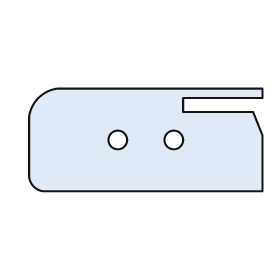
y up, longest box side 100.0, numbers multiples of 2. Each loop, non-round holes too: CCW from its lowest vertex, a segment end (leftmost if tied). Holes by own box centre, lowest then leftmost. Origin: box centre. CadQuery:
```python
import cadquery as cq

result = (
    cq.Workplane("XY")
    .moveTo(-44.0, -22.0)
    .lineTo(50.0, -22.0)
    .lineTo(50.0, 2.0)
    .lineTo(46.0, 12.0)
    .lineTo(16.0, 12.0)
    .lineTo(16.0, 18.0)
    .lineTo(50.0, 18.0)
    .lineTo(50.0, 22.0)
    .lineTo(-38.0, 22.0)
    .threePointArc((-46.0, 18.0), (-50.0, 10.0))
    .lineTo(-50.0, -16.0)
    .threePointArc((-48.0, -20.0), (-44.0, -22.0))
    .close()
    .moveTo(-12.0, 0.0)
    .circle(4.0)
    .moveTo(12.0, 0.0)
    .circle(4.0)
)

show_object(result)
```